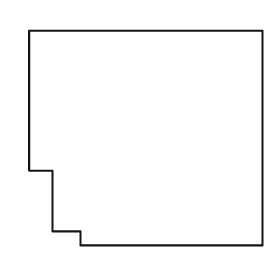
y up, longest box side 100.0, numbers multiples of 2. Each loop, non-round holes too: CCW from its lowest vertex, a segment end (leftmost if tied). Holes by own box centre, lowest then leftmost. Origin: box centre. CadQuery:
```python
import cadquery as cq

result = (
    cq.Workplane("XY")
    .moveTo(-28.0, -46.0)
    .lineTo(50.0, -46.0)
    .lineTo(50.0, 46.0)
    .lineTo(-50.0, 46.0)
    .lineTo(-50.0, -14.0)
    .lineTo(-40.0, -14.0)
    .lineTo(-40.0, -40.0)
    .lineTo(-28.0, -40.0)
    .close()
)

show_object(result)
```